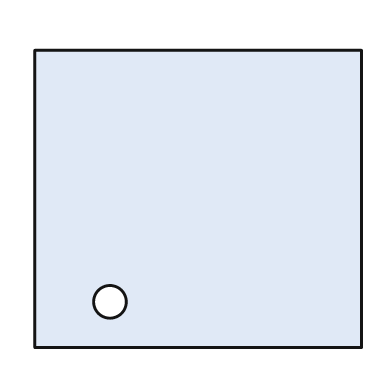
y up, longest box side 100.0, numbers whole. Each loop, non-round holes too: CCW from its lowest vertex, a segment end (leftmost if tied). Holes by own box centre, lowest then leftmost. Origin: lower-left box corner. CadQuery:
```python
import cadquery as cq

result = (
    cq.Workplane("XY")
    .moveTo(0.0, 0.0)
    .lineTo(100.0, 0.0)
    .lineTo(100.0, 91.0)
    .lineTo(0.0, 91.0)
    .close()
    .moveTo(23.0, 14.0)
    .circle(5.0)
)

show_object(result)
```